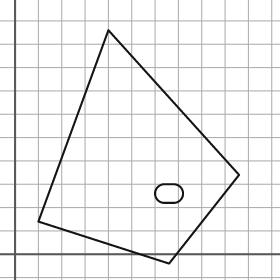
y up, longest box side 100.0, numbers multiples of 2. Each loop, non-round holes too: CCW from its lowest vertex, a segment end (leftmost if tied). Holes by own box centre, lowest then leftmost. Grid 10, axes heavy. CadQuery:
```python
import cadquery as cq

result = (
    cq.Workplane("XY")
    .moveTo(66.0, -4.0)
    .lineTo(96.0, 34.0)
    .lineTo(40.0, 96.0)
    .lineTo(10.0, 14.0)
    .close()
    .moveTo(64.0, 22.0)
    .lineTo(68.0, 22.0)
    .threePointArc((72.0, 26.0), (68.0, 30.0))
    .lineTo(64.0, 30.0)
    .threePointArc((60.0, 26.0), (64.0, 22.0))
    .close()
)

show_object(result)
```